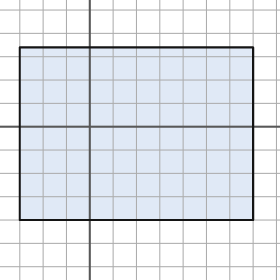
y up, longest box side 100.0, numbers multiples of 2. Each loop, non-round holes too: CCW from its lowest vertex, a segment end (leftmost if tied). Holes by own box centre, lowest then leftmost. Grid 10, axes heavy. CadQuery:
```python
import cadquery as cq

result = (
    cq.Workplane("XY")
    .moveTo(-30.0, -40.0)
    .lineTo(70.0, -40.0)
    .lineTo(70.0, 34.0)
    .lineTo(-30.0, 34.0)
    .close()
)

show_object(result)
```